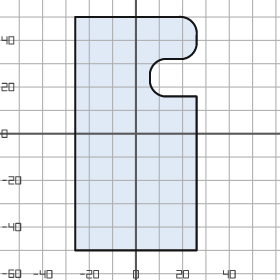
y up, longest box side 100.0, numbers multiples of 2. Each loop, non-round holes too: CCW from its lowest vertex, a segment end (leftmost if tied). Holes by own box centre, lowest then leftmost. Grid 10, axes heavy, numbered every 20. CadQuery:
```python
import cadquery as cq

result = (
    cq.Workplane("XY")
    .moveTo(-26.0, -50.0)
    .lineTo(26.0, -50.0)
    .lineTo(26.0, 16.0)
    .lineTo(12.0, 16.0)
    .threePointArc((8.0, 18.0), (6.0, 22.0))
    .lineTo(6.0, 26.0)
    .threePointArc((8.0, 30.0), (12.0, 32.0))
    .lineTo(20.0, 32.0)
    .threePointArc((24.0, 34.0), (26.0, 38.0))
    .lineTo(26.0, 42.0)
    .threePointArc((24.0, 48.0), (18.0, 50.0))
    .lineTo(-26.0, 50.0)
    .close()
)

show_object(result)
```